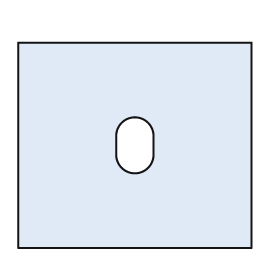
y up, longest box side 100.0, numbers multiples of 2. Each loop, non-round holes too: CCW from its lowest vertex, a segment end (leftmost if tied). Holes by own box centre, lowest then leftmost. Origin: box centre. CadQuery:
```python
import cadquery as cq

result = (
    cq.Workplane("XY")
    .moveTo(-50.0, -44.0)
    .lineTo(50.0, -44.0)
    .lineTo(50.0, 44.0)
    .lineTo(-50.0, 44.0)
    .close()
    .moveTo(-8.0, -4.0)
    .threePointArc((0.0, -12.0), (8.0, -4.0))
    .lineTo(8.0, 4.0)
    .threePointArc((0.0, 12.0), (-8.0, 4.0))
    .close()
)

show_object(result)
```